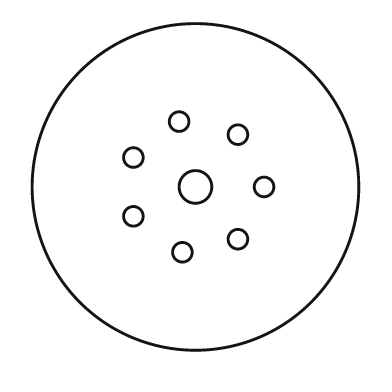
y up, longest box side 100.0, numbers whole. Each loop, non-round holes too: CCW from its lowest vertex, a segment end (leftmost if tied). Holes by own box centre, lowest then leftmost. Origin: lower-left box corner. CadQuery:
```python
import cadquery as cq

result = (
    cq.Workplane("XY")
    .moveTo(50.0, 50.0)
    .circle(50.0)
    .moveTo(46.0, 30.0)
    .circle(3.0)
    .moveTo(63.0, 34.0)
    .circle(3.0)
    .moveTo(31.0, 41.0)
    .circle(3.0)
    .moveTo(50.0, 50.0)
    .circle(5.0)
    .moveTo(71.0, 50.0)
    .circle(3.0)
    .moveTo(31.0, 59.0)
    .circle(3.0)
    .moveTo(63.0, 66.0)
    .circle(3.0)
    .moveTo(45.0, 70.0)
    .circle(3.0)
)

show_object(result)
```